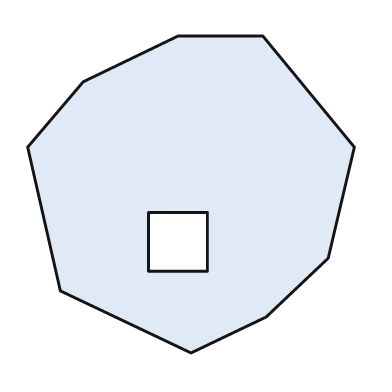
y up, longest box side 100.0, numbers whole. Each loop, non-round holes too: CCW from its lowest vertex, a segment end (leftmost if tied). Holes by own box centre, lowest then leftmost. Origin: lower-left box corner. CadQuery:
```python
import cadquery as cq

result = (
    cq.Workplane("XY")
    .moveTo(50.0, 0.0)
    .lineTo(73.0, 11.0)
    .lineTo(92.0, 29.0)
    .lineTo(100.0, 63.0)
    .lineTo(72.0, 97.0)
    .lineTo(46.0, 97.0)
    .lineTo(17.0, 83.0)
    .lineTo(0.0, 63.0)
    .lineTo(10.0, 19.0)
    .close()
    .moveTo(37.0, 25.0)
    .lineTo(55.0, 25.0)
    .lineTo(55.0, 43.0)
    .lineTo(37.0, 43.0)
    .close()
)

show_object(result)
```